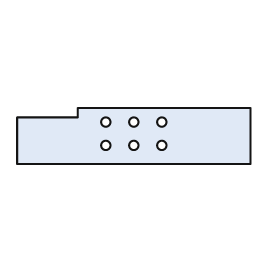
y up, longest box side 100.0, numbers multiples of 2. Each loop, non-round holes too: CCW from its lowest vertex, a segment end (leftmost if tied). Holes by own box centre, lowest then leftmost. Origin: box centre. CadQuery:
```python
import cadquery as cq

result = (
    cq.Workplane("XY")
    .moveTo(-50.0, -12.0)
    .lineTo(50.0, -12.0)
    .lineTo(50.0, 12.0)
    .lineTo(-24.0, 12.0)
    .lineTo(-24.0, 8.0)
    .lineTo(-50.0, 8.0)
    .close()
    .moveTo(-12.0, -4.0)
    .circle(2.0)
    .moveTo(0.0, -4.0)
    .circle(2.0)
    .moveTo(12.0, -4.0)
    .circle(2.0)
    .moveTo(-12.0, 6.0)
    .circle(2.0)
    .moveTo(0.0, 6.0)
    .circle(2.0)
    .moveTo(12.0, 6.0)
    .circle(2.0)
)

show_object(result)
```